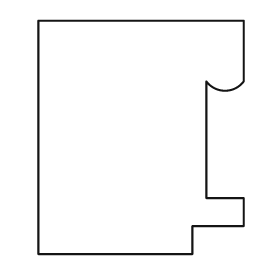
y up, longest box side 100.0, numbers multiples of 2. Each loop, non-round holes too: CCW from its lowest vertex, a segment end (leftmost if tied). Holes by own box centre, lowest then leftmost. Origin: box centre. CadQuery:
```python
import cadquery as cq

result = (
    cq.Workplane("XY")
    .moveTo(-44.0, -50.0)
    .lineTo(22.0, -50.0)
    .lineTo(22.0, -38.0)
    .lineTo(44.0, -38.0)
    .lineTo(44.0, -26.0)
    .lineTo(28.0, -26.0)
    .lineTo(28.0, 24.0)
    .threePointArc((36.0, 20.0), (44.0, 24.0))
    .lineTo(44.0, 50.0)
    .lineTo(-44.0, 50.0)
    .close()
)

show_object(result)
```